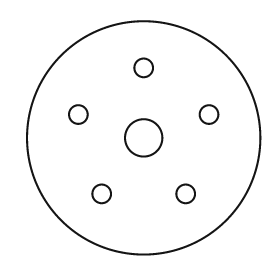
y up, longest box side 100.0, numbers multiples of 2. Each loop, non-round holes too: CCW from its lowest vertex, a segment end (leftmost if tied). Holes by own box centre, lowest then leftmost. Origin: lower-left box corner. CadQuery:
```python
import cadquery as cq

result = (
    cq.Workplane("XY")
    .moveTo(50.0, 50.0)
    .circle(50.0)
    .moveTo(32.0, 26.0)
    .circle(4.0)
    .moveTo(68.0, 26.0)
    .circle(4.0)
    .moveTo(50.0, 50.0)
    .circle(8.0)
    .moveTo(22.0, 60.0)
    .circle(4.0)
    .moveTo(78.0, 60.0)
    .circle(4.0)
    .moveTo(50.0, 80.0)
    .circle(4.0)
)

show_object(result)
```